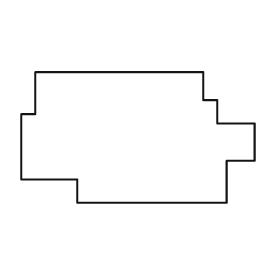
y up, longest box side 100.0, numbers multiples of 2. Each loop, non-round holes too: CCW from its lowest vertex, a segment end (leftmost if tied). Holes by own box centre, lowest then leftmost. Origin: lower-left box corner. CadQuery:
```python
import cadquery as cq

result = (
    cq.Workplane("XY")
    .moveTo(24.0, 0.0)
    .lineTo(88.0, 0.0)
    .lineTo(88.0, 18.0)
    .lineTo(100.0, 18.0)
    .lineTo(100.0, 34.0)
    .lineTo(84.0, 34.0)
    .lineTo(84.0, 44.0)
    .lineTo(78.0, 44.0)
    .lineTo(78.0, 56.0)
    .lineTo(6.0, 56.0)
    .lineTo(6.0, 38.0)
    .lineTo(0.0, 38.0)
    .lineTo(0.0, 10.0)
    .lineTo(24.0, 10.0)
    .close()
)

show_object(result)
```